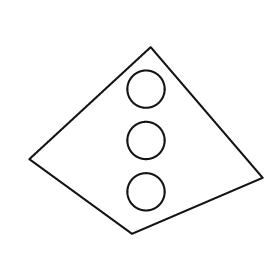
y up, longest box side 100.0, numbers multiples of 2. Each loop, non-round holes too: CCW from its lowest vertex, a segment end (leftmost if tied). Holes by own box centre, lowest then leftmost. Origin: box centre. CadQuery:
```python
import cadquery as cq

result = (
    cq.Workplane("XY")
    .moveTo(-6.0, -40.0)
    .lineTo(50.0, -16.0)
    .lineTo(2.0, 40.0)
    .lineTo(-50.0, -8.0)
    .close()
    .moveTo(0.0, -22.0)
    .circle(8.0)
    .moveTo(0.0, 0.0)
    .circle(8.0)
    .moveTo(0.0, 22.0)
    .circle(8.0)
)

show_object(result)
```